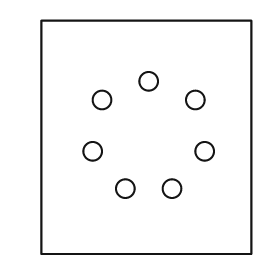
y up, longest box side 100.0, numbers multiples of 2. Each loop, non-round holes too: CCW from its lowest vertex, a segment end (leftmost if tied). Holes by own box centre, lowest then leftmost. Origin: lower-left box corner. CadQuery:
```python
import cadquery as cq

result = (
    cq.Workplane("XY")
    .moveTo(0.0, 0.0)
    .lineTo(90.0, 0.0)
    .lineTo(90.0, 100.0)
    .lineTo(0.0, 100.0)
    .close()
    .moveTo(36.0, 28.0)
    .circle(4.0)
    .moveTo(56.0, 28.0)
    .circle(4.0)
    .moveTo(22.0, 44.0)
    .circle(4.0)
    .moveTo(70.0, 44.0)
    .circle(4.0)
    .moveTo(26.0, 66.0)
    .circle(4.0)
    .moveTo(66.0, 66.0)
    .circle(4.0)
    .moveTo(46.0, 74.0)
    .circle(4.0)
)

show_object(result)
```